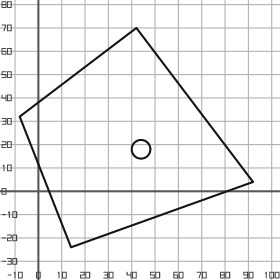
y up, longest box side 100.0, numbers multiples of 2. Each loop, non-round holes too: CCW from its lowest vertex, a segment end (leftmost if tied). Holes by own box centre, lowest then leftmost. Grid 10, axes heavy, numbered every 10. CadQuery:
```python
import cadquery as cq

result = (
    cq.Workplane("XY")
    .moveTo(14.0, -24.0)
    .lineTo(92.0, 4.0)
    .lineTo(42.0, 70.0)
    .lineTo(-8.0, 32.0)
    .close()
    .moveTo(44.0, 18.0)
    .circle(4.0)
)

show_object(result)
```